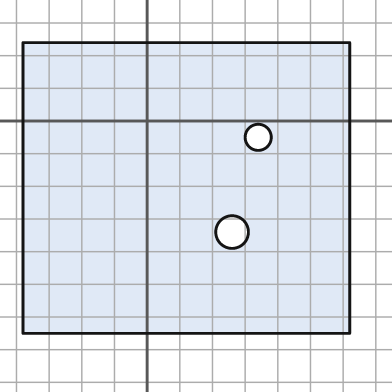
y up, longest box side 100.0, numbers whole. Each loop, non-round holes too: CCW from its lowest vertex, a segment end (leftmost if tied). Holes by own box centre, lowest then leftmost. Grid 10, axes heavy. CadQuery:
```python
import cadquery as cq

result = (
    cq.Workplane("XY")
    .moveTo(-38.0, -65.0)
    .lineTo(62.0, -65.0)
    .lineTo(62.0, 24.0)
    .lineTo(-38.0, 24.0)
    .close()
    .moveTo(26.0, -34.0)
    .circle(5.0)
    .moveTo(34.0, -5.0)
    .circle(4.0)
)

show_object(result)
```